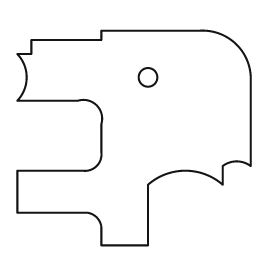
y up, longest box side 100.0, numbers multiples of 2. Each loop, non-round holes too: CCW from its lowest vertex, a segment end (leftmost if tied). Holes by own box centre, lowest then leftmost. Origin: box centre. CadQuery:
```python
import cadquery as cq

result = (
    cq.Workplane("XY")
    .moveTo(-14.0, -46.0)
    .lineTo(6.0, -46.0)
    .lineTo(6.0, -20.0)
    .threePointArc((22.0, -14.0), (38.0, -20.0))
    .lineTo(38.0, -12.0)
    .threePointArc((44.0, -10.0), (50.0, -12.0))
    .lineTo(50.0, 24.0)
    .threePointArc((44.0, 40.0), (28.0, 46.0))
    .lineTo(-14.0, 46.0)
    .lineTo(-14.0, 42.0)
    .lineTo(-44.0, 42.0)
    .lineTo(-44.0, 36.0)
    .lineTo(-50.0, 36.0)
    .threePointArc((-46.0, 26.0), (-50.0, 16.0))
    .lineTo(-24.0, 16.0)
    .threePointArc((-16.0, 14.0), (-14.0, 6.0))
    .lineTo(-14.0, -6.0)
    .threePointArc((-16.0, -12.0), (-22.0, -14.0))
    .lineTo(-50.0, -14.0)
    .lineTo(-50.0, -32.0)
    .lineTo(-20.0, -32.0)
    .threePointArc((-16.0, -34.0), (-14.0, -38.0))
    .close()
    .moveTo(6.0, 26.0)
    .circle(4.0)
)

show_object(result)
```